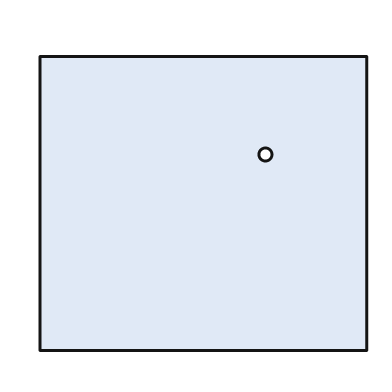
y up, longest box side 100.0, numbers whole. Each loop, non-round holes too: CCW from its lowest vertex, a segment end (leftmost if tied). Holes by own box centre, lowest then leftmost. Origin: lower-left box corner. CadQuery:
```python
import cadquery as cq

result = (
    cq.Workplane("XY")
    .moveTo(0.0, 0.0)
    .lineTo(100.0, 0.0)
    .lineTo(100.0, 90.0)
    .lineTo(0.0, 90.0)
    .close()
    .moveTo(69.0, 60.0)
    .circle(2.0)
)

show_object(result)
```